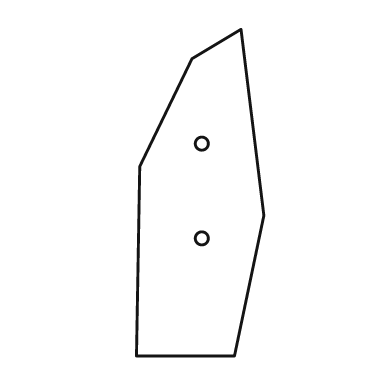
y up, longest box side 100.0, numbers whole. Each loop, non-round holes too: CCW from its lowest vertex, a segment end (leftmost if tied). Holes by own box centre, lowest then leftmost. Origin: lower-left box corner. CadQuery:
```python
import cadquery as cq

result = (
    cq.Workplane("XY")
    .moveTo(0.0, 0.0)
    .lineTo(30.0, 0.0)
    .lineTo(39.0, 43.0)
    .lineTo(32.0, 100.0)
    .lineTo(17.0, 91.0)
    .lineTo(1.0, 58.0)
    .close()
    .moveTo(20.0, 36.0)
    .circle(2.0)
    .moveTo(20.0, 65.0)
    .circle(2.0)
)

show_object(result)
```